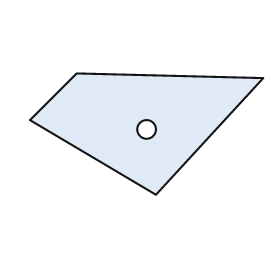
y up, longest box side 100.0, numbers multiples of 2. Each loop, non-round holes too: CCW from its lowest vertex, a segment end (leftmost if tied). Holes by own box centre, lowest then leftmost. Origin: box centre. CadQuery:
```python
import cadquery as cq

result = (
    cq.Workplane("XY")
    .moveTo(4.0, -26.0)
    .lineTo(50.0, 24.0)
    .lineTo(-30.0, 26.0)
    .lineTo(-50.0, 6.0)
    .close()
    .moveTo(0.0, 2.0)
    .circle(4.0)
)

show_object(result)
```